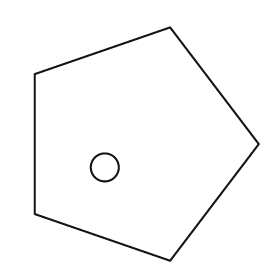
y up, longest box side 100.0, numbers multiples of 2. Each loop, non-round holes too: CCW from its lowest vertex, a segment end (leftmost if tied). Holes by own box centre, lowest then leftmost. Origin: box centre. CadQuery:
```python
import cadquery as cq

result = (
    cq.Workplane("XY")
    .moveTo(10.0, -50.0)
    .lineTo(48.0, 0.0)
    .lineTo(10.0, 50.0)
    .lineTo(-48.0, 30.0)
    .lineTo(-48.0, -30.0)
    .close()
    .moveTo(-18.0, -10.0)
    .circle(6.0)
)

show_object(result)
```